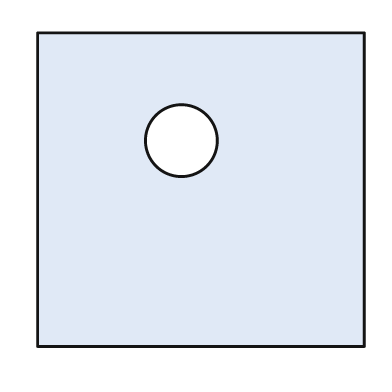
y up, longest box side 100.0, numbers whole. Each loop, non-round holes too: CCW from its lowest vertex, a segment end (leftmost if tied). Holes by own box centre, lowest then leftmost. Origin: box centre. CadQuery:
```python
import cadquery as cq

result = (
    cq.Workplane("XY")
    .moveTo(-50.0, -48.0)
    .lineTo(50.0, -48.0)
    .lineTo(50.0, 48.0)
    .lineTo(-50.0, 48.0)
    .close()
    .moveTo(-6.0, 15.0)
    .circle(11.0)
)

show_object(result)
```